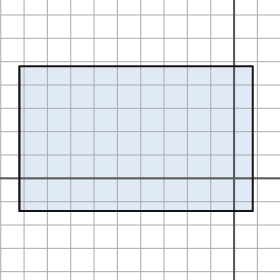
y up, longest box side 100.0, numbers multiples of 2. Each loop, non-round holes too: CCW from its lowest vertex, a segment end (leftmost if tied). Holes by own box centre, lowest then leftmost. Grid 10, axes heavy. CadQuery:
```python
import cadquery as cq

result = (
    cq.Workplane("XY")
    .moveTo(-92.0, -14.0)
    .lineTo(8.0, -14.0)
    .lineTo(8.0, 48.0)
    .lineTo(-92.0, 48.0)
    .close()
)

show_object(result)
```